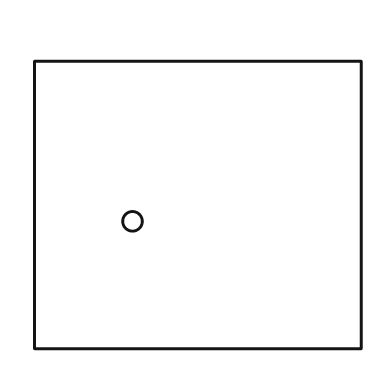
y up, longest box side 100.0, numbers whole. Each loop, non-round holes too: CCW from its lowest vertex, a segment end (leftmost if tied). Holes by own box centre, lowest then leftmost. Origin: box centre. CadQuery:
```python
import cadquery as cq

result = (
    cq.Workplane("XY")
    .moveTo(-50.0, -44.0)
    .lineTo(50.0, -44.0)
    .lineTo(50.0, 44.0)
    .lineTo(-50.0, 44.0)
    .close()
    .moveTo(-20.0, -5.0)
    .circle(3.0)
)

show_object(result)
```